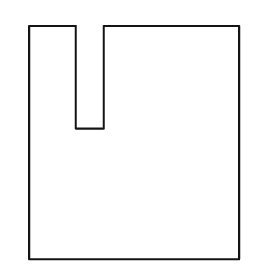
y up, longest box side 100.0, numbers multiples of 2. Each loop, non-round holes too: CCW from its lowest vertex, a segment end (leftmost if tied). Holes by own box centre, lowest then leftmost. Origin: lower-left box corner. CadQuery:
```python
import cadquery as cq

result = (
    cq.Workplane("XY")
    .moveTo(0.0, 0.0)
    .lineTo(90.0, 0.0)
    .lineTo(90.0, 100.0)
    .lineTo(32.0, 100.0)
    .lineTo(32.0, 56.0)
    .lineTo(20.0, 56.0)
    .lineTo(20.0, 100.0)
    .lineTo(0.0, 100.0)
    .close()
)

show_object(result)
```